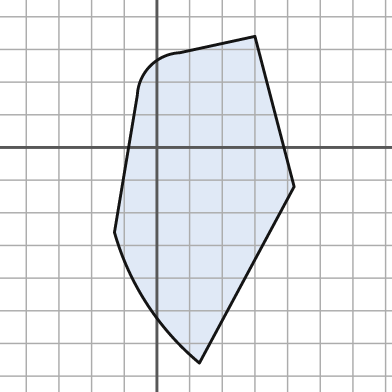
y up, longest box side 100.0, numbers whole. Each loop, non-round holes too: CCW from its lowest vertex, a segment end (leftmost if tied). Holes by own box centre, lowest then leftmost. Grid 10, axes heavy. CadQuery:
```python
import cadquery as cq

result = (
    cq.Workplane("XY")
    .moveTo(13.0, -66.0)
    .lineTo(42.0, -12.0)
    .lineTo(30.0, 34.0)
    .lineTo(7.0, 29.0)
    .threePointArc((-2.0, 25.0), (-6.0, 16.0))
    .lineTo(-13.0, -26.0)
    .threePointArc((-3.0, -48.0), (13.0, -66.0))
    .close()
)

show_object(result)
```